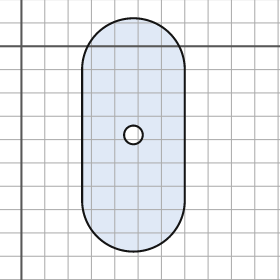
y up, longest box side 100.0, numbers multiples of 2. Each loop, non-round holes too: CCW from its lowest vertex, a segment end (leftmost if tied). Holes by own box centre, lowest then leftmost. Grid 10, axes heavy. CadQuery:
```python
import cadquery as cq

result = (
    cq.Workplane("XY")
    .moveTo(26.0, -66.0)
    .threePointArc((48.0, -88.0), (70.0, -66.0))
    .lineTo(70.0, -10.0)
    .threePointArc((48.0, 12.0), (26.0, -10.0))
    .close()
    .moveTo(48.0, -38.0)
    .circle(4.0)
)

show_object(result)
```